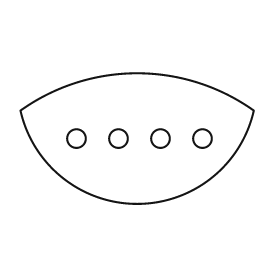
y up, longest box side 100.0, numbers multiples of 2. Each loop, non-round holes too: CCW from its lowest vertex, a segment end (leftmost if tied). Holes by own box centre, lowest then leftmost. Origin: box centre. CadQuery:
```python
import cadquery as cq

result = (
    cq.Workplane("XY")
    .moveTo(-50.0, 12.0)
    .threePointArc((0.0, -28.0), (50.0, 12.0))
    .threePointArc((0.0, 28.0), (-50.0, 12.0))
    .close()
    .moveTo(-26.0, 0.0)
    .circle(4.0)
    .moveTo(-8.0, 0.0)
    .circle(4.0)
    .moveTo(10.0, 0.0)
    .circle(4.0)
    .moveTo(28.0, 0.0)
    .circle(4.0)
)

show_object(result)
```